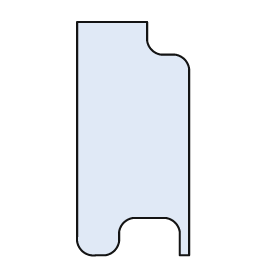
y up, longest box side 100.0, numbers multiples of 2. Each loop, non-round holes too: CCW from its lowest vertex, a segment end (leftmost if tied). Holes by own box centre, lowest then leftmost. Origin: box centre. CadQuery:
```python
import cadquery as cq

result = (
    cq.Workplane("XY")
    .moveTo(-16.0, -50.0)
    .lineTo(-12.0, -50.0)
    .threePointArc((-8.0, -48.0), (-6.0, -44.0))
    .lineTo(-6.0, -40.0)
    .threePointArc((-4.0, -36.0), (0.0, -34.0))
    .lineTo(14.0, -34.0)
    .threePointArc((18.0, -36.0), (20.0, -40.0))
    .lineTo(20.0, -50.0)
    .lineTo(24.0, -50.0)
    .lineTo(24.0, 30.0)
    .threePointArc((22.0, 34.0), (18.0, 36.0))
    .lineTo(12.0, 36.0)
    .threePointArc((8.0, 38.0), (6.0, 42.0))
    .lineTo(6.0, 50.0)
    .lineTo(-24.0, 50.0)
    .lineTo(-24.0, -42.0)
    .threePointArc((-22.0, -48.0), (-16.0, -50.0))
    .close()
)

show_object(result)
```